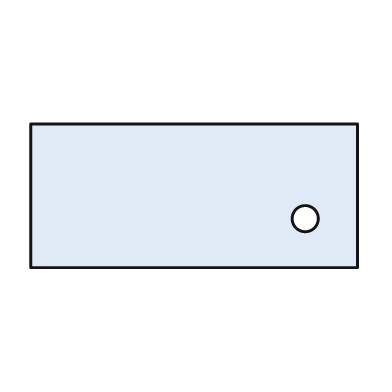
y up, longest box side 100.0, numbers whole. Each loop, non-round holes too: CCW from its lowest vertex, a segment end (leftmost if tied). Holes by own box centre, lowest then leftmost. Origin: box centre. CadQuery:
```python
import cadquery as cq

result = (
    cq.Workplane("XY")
    .moveTo(-50.0, -22.0)
    .lineTo(50.0, -22.0)
    .lineTo(50.0, 22.0)
    .lineTo(-50.0, 22.0)
    .close()
    .moveTo(34.0, -7.0)
    .circle(4.0)
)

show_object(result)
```